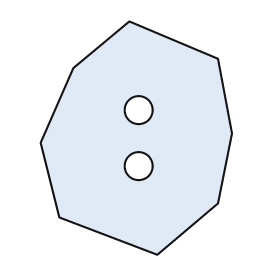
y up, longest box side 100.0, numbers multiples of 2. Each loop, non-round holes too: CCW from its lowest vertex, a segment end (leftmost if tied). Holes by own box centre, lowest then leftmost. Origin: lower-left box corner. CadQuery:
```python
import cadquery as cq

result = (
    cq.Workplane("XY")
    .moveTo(50.0, 0.0)
    .lineTo(76.0, 22.0)
    .lineTo(82.0, 52.0)
    .lineTo(76.0, 84.0)
    .lineTo(38.0, 100.0)
    .lineTo(14.0, 80.0)
    .lineTo(0.0, 48.0)
    .lineTo(8.0, 16.0)
    .close()
    .moveTo(42.0, 38.0)
    .circle(6.0)
    .moveTo(42.0, 62.0)
    .circle(6.0)
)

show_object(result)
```